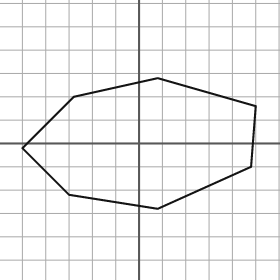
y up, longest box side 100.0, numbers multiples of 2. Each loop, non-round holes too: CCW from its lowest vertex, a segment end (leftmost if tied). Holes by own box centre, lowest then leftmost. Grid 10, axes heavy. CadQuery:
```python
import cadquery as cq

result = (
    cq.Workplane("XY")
    .moveTo(8.0, -28.0)
    .lineTo(48.0, -10.0)
    .lineTo(50.0, 16.0)
    .lineTo(8.0, 28.0)
    .lineTo(-28.0, 20.0)
    .lineTo(-50.0, -2.0)
    .lineTo(-30.0, -22.0)
    .close()
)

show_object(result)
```